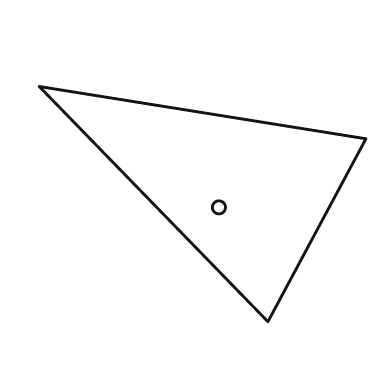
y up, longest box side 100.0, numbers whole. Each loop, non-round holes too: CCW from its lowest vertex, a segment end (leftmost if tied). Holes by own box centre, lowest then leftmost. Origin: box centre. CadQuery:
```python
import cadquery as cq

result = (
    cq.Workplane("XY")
    .moveTo(20.0, -36.0)
    .lineTo(50.0, 20.0)
    .lineTo(-50.0, 36.0)
    .close()
    .moveTo(5.0, -1.0)
    .circle(2.0)
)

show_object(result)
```